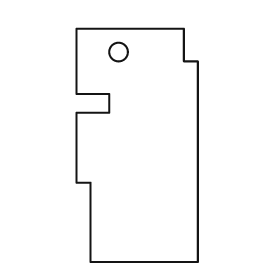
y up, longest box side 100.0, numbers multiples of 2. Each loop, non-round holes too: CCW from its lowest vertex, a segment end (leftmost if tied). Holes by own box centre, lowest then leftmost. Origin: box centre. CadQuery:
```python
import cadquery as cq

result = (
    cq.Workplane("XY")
    .moveTo(-20.0, -50.0)
    .lineTo(26.0, -50.0)
    .lineTo(26.0, 36.0)
    .lineTo(20.0, 36.0)
    .lineTo(20.0, 50.0)
    .lineTo(-26.0, 50.0)
    .lineTo(-26.0, 22.0)
    .lineTo(-12.0, 22.0)
    .lineTo(-12.0, 14.0)
    .lineTo(-26.0, 14.0)
    .lineTo(-26.0, -16.0)
    .lineTo(-20.0, -16.0)
    .close()
    .moveTo(-8.0, 40.0)
    .circle(4.0)
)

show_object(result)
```